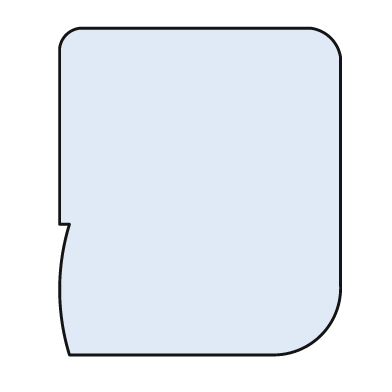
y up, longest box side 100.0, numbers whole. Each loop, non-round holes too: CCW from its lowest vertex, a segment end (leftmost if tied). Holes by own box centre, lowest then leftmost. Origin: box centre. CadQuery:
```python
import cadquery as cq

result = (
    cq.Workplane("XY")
    .moveTo(-40.0, -50.0)
    .lineTo(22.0, -50.0)
    .threePointArc((37.0, -44.0), (43.0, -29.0))
    .lineTo(43.0, 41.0)
    .threePointArc((40.0, 47.0), (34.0, 50.0))
    .lineTo(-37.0, 50.0)
    .threePointArc((-41.0, 48.0), (-43.0, 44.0))
    .lineTo(-43.0, -10.0)
    .lineTo(-40.0, -10.0)
    .threePointArc((-43.0, -30.0), (-40.0, -50.0))
    .close()
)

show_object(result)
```